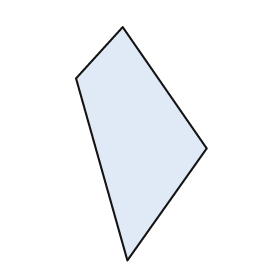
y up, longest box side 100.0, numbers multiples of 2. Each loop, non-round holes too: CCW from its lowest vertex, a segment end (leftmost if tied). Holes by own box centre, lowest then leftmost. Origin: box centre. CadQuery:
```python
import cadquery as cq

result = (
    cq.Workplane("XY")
    .moveTo(-6.0, -50.0)
    .lineTo(28.0, -2.0)
    .lineTo(-8.0, 50.0)
    .lineTo(-28.0, 28.0)
    .close()
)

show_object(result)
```